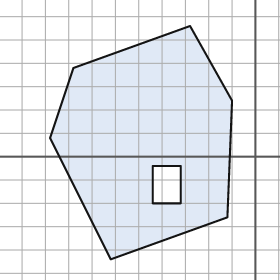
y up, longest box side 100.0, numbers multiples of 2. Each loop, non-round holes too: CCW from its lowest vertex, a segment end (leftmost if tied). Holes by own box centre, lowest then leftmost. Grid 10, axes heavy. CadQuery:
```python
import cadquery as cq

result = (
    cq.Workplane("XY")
    .moveTo(-62.0, -44.0)
    .lineTo(-12.0, -26.0)
    .lineTo(-10.0, 24.0)
    .lineTo(-28.0, 56.0)
    .lineTo(-78.0, 38.0)
    .lineTo(-88.0, 8.0)
    .close()
    .moveTo(-44.0, -20.0)
    .lineTo(-32.0, -20.0)
    .lineTo(-32.0, -4.0)
    .lineTo(-44.0, -4.0)
    .close()
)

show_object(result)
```